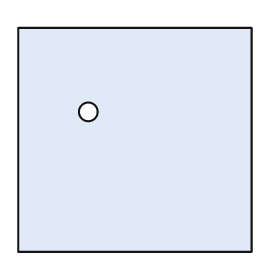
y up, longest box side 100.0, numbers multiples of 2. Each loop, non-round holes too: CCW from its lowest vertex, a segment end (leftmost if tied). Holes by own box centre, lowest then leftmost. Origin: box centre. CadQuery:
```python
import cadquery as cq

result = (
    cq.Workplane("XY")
    .moveTo(-50.0, -48.0)
    .lineTo(50.0, -48.0)
    .lineTo(50.0, 48.0)
    .lineTo(-50.0, 48.0)
    .close()
    .moveTo(-20.0, 12.0)
    .circle(4.0)
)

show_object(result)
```